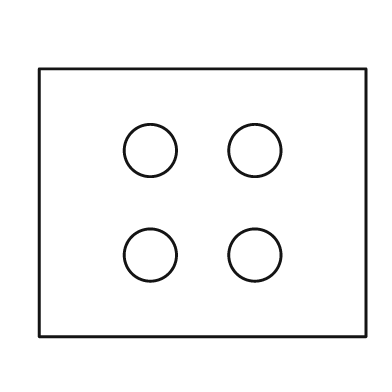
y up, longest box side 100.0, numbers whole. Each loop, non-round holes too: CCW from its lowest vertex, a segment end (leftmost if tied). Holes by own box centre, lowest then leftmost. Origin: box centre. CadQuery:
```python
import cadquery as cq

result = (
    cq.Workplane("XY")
    .moveTo(-50.0, -41.0)
    .lineTo(50.0, -41.0)
    .lineTo(50.0, 41.0)
    .lineTo(-50.0, 41.0)
    .close()
    .moveTo(-16.0, -16.0)
    .circle(8.0)
    .moveTo(16.0, -16.0)
    .circle(8.0)
    .moveTo(-16.0, 16.0)
    .circle(8.0)
    .moveTo(16.0, 16.0)
    .circle(8.0)
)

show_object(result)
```